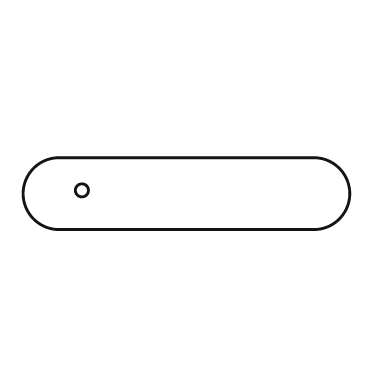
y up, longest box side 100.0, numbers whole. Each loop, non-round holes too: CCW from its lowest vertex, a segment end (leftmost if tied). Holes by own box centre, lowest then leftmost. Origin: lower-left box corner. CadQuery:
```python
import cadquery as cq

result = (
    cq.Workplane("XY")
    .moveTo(11.0, 0.0)
    .lineTo(89.0, 0.0)
    .threePointArc((100.0, 11.0), (89.0, 22.0))
    .lineTo(11.0, 22.0)
    .threePointArc((0.0, 11.0), (11.0, 0.0))
    .close()
    .moveTo(18.0, 12.0)
    .circle(2.0)
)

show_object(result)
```